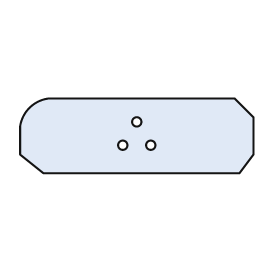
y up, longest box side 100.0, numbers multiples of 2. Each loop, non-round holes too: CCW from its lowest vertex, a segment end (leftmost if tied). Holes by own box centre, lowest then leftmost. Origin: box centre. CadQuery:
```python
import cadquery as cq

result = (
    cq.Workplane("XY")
    .moveTo(-40.0, -16.0)
    .lineTo(44.0, -16.0)
    .lineTo(50.0, -8.0)
    .lineTo(50.0, 8.0)
    .lineTo(42.0, 16.0)
    .lineTo(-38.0, 16.0)
    .threePointArc((-46.0, 12.0), (-50.0, 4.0))
    .lineTo(-50.0, -8.0)
    .close()
    .moveTo(-6.0, -4.0)
    .circle(2.0)
    .moveTo(6.0, -4.0)
    .circle(2.0)
    .moveTo(0.0, 6.0)
    .circle(2.0)
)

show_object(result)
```